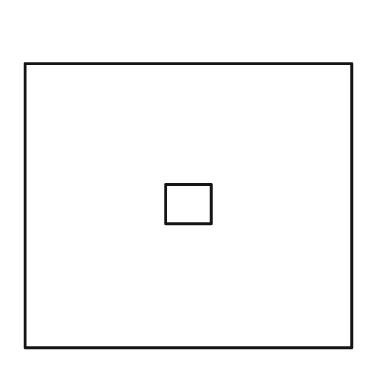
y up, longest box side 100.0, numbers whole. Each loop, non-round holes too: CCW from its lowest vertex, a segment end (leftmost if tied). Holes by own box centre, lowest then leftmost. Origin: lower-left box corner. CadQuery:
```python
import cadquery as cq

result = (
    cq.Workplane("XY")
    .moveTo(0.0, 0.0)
    .lineTo(100.0, 0.0)
    .lineTo(100.0, 87.0)
    .lineTo(0.0, 87.0)
    .close()
    .moveTo(43.0, 38.0)
    .lineTo(57.0, 38.0)
    .lineTo(57.0, 50.0)
    .lineTo(43.0, 50.0)
    .close()
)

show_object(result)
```